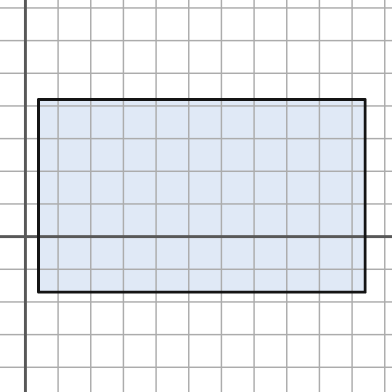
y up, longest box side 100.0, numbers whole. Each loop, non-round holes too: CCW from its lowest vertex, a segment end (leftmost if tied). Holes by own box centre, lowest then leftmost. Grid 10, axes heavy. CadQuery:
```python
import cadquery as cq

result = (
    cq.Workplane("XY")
    .moveTo(4.0, -17.0)
    .lineTo(104.0, -17.0)
    .lineTo(104.0, 42.0)
    .lineTo(4.0, 42.0)
    .close()
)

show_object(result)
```